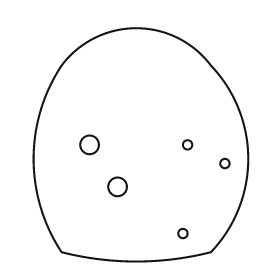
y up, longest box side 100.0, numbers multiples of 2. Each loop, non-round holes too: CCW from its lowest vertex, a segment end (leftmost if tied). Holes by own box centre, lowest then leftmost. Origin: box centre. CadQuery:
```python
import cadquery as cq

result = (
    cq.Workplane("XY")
    .moveTo(-34.0, -46.0)
    .threePointArc((-2.0, -50.0), (30.0, -46.0))
    .threePointArc((46.0, -6.0), (30.0, 34.0))
    .threePointArc((-2.0, 50.0), (-34.0, 34.0))
    .threePointArc((-46.0, -6.0), (-34.0, -46.0))
    .close()
    .moveTo(18.0, -38.0)
    .circle(2.0)
    .moveTo(-10.0, -18.0)
    .circle(4.0)
    .moveTo(36.0, -8.0)
    .circle(2.0)
    .moveTo(-22.0, 0.0)
    .circle(4.0)
    .moveTo(20.0, 0.0)
    .circle(2.0)
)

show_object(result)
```